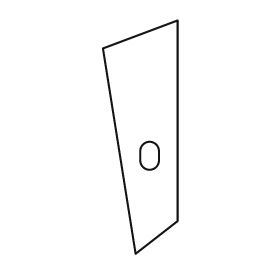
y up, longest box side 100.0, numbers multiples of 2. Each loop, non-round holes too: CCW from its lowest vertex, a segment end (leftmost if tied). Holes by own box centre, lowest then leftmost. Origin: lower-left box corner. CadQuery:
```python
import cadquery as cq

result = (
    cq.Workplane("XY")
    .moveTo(14.0, 0.0)
    .lineTo(32.0, 14.0)
    .lineTo(32.0, 100.0)
    .lineTo(0.0, 88.0)
    .close()
    .moveTo(16.0, 40.0)
    .threePointArc((20.0, 36.0), (24.0, 40.0))
    .lineTo(24.0, 44.0)
    .threePointArc((20.0, 48.0), (16.0, 44.0))
    .close()
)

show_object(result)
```